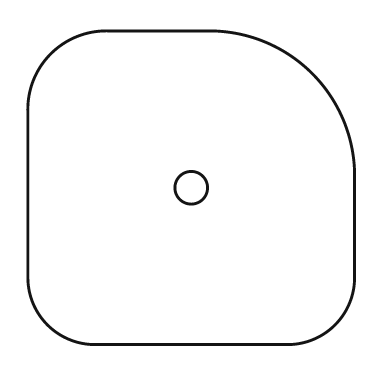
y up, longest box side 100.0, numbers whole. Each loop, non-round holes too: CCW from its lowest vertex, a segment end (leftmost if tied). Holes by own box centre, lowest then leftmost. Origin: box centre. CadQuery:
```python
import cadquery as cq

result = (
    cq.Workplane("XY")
    .moveTo(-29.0, -48.0)
    .lineTo(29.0, -48.0)
    .threePointArc((44.0, -42.0), (50.0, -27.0))
    .lineTo(50.0, 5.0)
    .threePointArc((37.0, 35.0), (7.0, 48.0))
    .lineTo(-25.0, 48.0)
    .threePointArc((-43.0, 41.0), (-50.0, 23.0))
    .lineTo(-50.0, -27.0)
    .threePointArc((-44.0, -42.0), (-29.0, -48.0))
    .close()
    .moveTo(0.0, 0.0)
    .circle(5.0)
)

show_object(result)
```